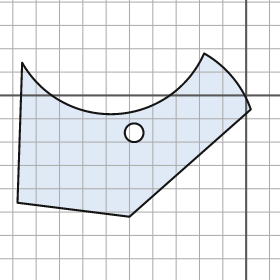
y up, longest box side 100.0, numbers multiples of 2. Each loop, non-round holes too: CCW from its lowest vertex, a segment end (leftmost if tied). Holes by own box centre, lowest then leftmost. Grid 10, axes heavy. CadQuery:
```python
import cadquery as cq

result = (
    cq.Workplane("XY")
    .moveTo(-50.0, -52.0)
    .lineTo(2.0, -6.0)
    .threePointArc((-6.0, 8.0), (-18.0, 18.0))
    .threePointArc((-56.0, -8.0), (-96.0, 14.0))
    .lineTo(-98.0, -46.0)
    .close()
    .moveTo(-48.0, -16.0)
    .circle(4.0)
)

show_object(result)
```